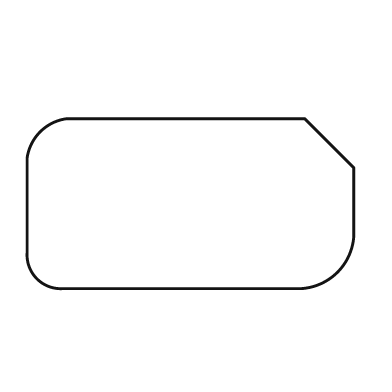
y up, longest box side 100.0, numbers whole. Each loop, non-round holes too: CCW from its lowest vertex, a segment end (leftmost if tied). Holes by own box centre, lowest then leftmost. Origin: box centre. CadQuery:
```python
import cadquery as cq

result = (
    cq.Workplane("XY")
    .moveTo(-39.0, -26.0)
    .lineTo(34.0, -26.0)
    .threePointArc((45.0, -21.0), (50.0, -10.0))
    .lineTo(50.0, 11.0)
    .lineTo(35.0, 26.0)
    .lineTo(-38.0, 26.0)
    .threePointArc((-46.0, 22.0), (-50.0, 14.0))
    .lineTo(-50.0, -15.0)
    .threePointArc((-47.0, -23.0), (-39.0, -26.0))
    .close()
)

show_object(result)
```